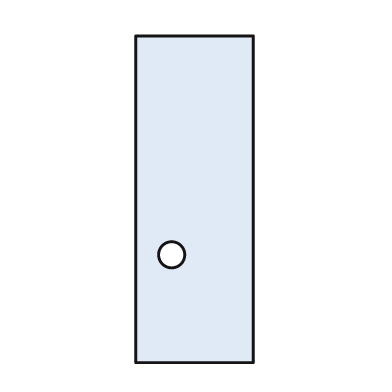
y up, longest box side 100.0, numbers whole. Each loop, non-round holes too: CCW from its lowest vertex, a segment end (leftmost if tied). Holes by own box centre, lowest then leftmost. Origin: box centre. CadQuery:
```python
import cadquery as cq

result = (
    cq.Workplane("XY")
    .moveTo(-18.0, -50.0)
    .lineTo(18.0, -50.0)
    .lineTo(18.0, 50.0)
    .lineTo(-18.0, 50.0)
    .close()
    .moveTo(-7.0, -17.0)
    .circle(4.0)
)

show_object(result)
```